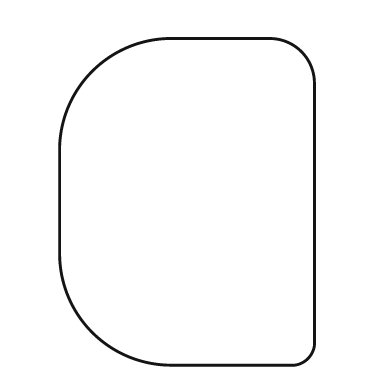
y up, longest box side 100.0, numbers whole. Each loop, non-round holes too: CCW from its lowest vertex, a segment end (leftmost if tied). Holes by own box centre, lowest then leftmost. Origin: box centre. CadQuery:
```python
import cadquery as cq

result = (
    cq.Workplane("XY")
    .moveTo(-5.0, -50.0)
    .lineTo(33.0, -50.0)
    .threePointArc((37.0, -48.0), (39.0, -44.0))
    .lineTo(39.0, 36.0)
    .threePointArc((35.0, 46.0), (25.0, 50.0))
    .lineTo(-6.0, 50.0)
    .threePointArc((-29.0, 40.0), (-39.0, 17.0))
    .lineTo(-39.0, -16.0)
    .threePointArc((-29.0, -40.0), (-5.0, -50.0))
    .close()
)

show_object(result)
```